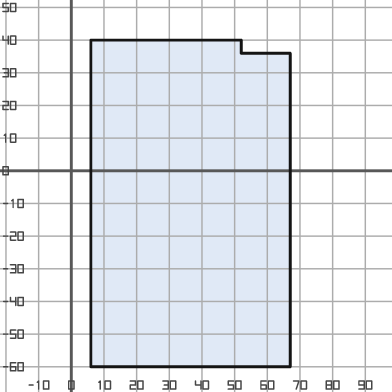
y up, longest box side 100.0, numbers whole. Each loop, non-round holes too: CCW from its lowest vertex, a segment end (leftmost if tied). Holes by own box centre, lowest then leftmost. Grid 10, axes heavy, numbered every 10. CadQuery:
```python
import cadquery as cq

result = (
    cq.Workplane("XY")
    .moveTo(6.0, -60.0)
    .lineTo(67.0, -60.0)
    .lineTo(67.0, 36.0)
    .lineTo(52.0, 36.0)
    .lineTo(52.0, 40.0)
    .lineTo(6.0, 40.0)
    .close()
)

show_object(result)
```